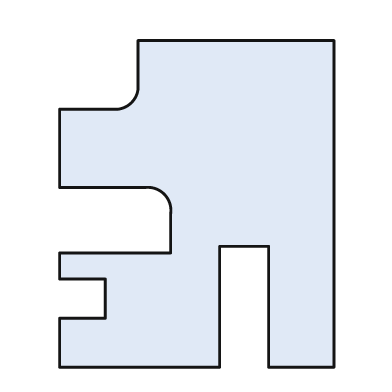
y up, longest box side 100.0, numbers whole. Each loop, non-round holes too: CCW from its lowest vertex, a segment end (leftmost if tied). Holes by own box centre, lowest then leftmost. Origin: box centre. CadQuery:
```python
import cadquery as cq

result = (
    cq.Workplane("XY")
    .moveTo(-42.0, -50.0)
    .lineTo(7.0, -50.0)
    .lineTo(7.0, -13.0)
    .lineTo(22.0, -13.0)
    .lineTo(22.0, -50.0)
    .lineTo(42.0, -50.0)
    .lineTo(42.0, 50.0)
    .lineTo(-18.0, 50.0)
    .lineTo(-18.0, 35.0)
    .threePointArc((-20.0, 31.0), (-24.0, 29.0))
    .lineTo(-42.0, 29.0)
    .lineTo(-42.0, 5.0)
    .lineTo(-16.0, 5.0)
    .threePointArc((-10.0, 3.0), (-8.0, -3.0))
    .lineTo(-8.0, -15.0)
    .lineTo(-42.0, -15.0)
    .lineTo(-42.0, -23.0)
    .lineTo(-28.0, -23.0)
    .lineTo(-28.0, -35.0)
    .lineTo(-42.0, -35.0)
    .close()
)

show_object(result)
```